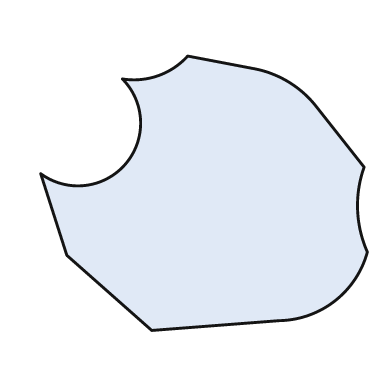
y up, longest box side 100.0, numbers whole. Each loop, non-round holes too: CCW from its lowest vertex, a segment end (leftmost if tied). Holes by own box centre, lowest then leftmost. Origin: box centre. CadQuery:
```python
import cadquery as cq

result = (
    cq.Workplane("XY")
    .moveTo(-16.0, -42.0)
    .lineTo(23.0, -39.0)
    .threePointArc((40.0, -33.0), (50.0, -18.0))
    .threePointArc((47.0, -5.0), (49.0, 8.0))
    .lineTo(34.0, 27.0)
    .threePointArc((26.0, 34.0), (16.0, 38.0))
    .lineTo(-5.0, 42.0)
    .threePointArc((-14.0, 36.0), (-25.0, 35.0))
    .threePointArc((-24.0, 9.0), (-50.0, 6.0))
    .lineTo(-42.0, -19.0)
    .close()
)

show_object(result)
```